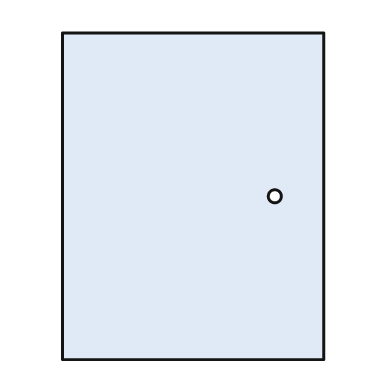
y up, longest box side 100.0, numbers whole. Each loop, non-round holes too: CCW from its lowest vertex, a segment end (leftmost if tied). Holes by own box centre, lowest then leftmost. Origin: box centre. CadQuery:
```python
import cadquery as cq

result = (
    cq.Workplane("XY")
    .moveTo(-40.0, -50.0)
    .lineTo(40.0, -50.0)
    .lineTo(40.0, 50.0)
    .lineTo(-40.0, 50.0)
    .close()
    .moveTo(25.0, 0.0)
    .circle(2.0)
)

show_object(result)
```